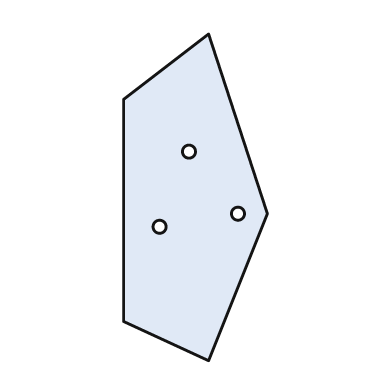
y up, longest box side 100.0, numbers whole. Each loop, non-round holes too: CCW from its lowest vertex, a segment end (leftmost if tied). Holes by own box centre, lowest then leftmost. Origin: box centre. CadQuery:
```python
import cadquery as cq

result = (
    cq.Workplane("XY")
    .moveTo(4.0, -50.0)
    .lineTo(22.0, -5.0)
    .lineTo(4.0, 50.0)
    .lineTo(-22.0, 30.0)
    .lineTo(-22.0, -38.0)
    .close()
    .moveTo(-11.0, -9.0)
    .circle(2.0)
    .moveTo(13.0, -5.0)
    .circle(2.0)
    .moveTo(-2.0, 14.0)
    .circle(2.0)
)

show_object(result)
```